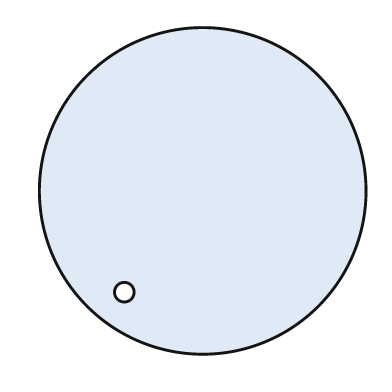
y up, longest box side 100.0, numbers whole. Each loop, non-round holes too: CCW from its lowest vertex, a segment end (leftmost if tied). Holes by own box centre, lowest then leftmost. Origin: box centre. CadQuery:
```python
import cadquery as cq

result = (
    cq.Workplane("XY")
    .moveTo(0.0, 0.0)
    .circle(50.0)
    .moveTo(-24.0, -31.0)
    .circle(3.0)
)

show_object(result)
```